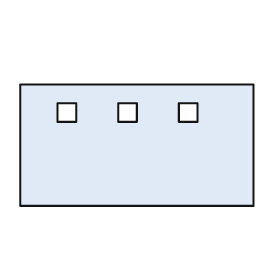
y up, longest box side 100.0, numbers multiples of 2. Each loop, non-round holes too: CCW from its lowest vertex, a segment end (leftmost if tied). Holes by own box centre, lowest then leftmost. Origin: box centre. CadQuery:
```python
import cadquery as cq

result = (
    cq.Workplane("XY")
    .moveTo(-50.0, -26.0)
    .lineTo(50.0, -26.0)
    .lineTo(50.0, 26.0)
    .lineTo(-50.0, 26.0)
    .close()
    .moveTo(-34.0, 10.0)
    .lineTo(-26.0, 10.0)
    .lineTo(-26.0, 18.0)
    .lineTo(-34.0, 18.0)
    .close()
    .moveTo(-8.0, 10.0)
    .lineTo(0.0, 10.0)
    .lineTo(0.0, 18.0)
    .lineTo(-8.0, 18.0)
    .close()
    .moveTo(18.0, 10.0)
    .lineTo(26.0, 10.0)
    .lineTo(26.0, 18.0)
    .lineTo(18.0, 18.0)
    .close()
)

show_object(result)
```